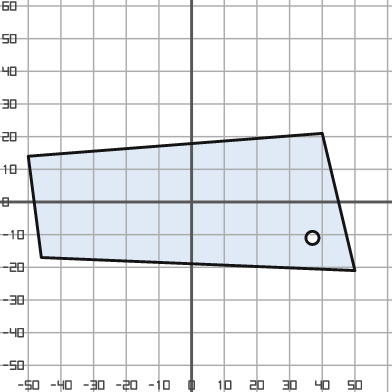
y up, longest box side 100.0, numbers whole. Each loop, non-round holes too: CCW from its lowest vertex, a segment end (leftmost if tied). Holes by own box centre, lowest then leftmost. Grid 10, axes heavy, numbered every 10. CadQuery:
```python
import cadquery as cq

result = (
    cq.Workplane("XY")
    .moveTo(50.0, -21.0)
    .lineTo(40.0, 21.0)
    .lineTo(-50.0, 14.0)
    .lineTo(-46.0, -17.0)
    .close()
    .moveTo(37.0, -11.0)
    .circle(2.0)
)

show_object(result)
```